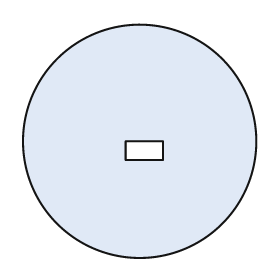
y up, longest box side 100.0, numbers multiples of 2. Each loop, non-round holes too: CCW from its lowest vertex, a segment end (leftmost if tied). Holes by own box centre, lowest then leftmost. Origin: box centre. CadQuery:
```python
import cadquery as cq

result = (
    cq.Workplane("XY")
    .moveTo(0.0, 0.0)
    .circle(50.0)
    .moveTo(-6.0, -8.0)
    .lineTo(10.0, -8.0)
    .lineTo(10.0, 0.0)
    .lineTo(-6.0, 0.0)
    .close()
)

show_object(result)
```